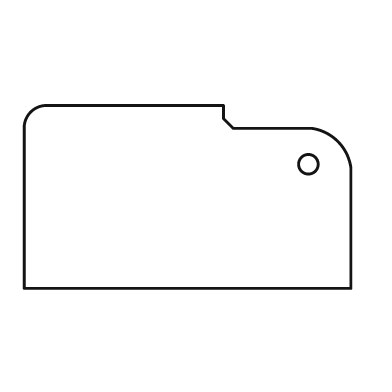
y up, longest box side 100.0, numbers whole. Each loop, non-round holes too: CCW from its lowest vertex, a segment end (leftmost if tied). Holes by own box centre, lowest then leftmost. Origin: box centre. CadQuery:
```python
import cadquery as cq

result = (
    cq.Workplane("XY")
    .moveTo(-50.0, -28.0)
    .lineTo(50.0, -28.0)
    .lineTo(50.0, 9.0)
    .threePointArc((46.0, 17.0), (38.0, 21.0))
    .lineTo(14.0, 21.0)
    .lineTo(11.0, 24.0)
    .lineTo(11.0, 28.0)
    .lineTo(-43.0, 28.0)
    .threePointArc((-48.0, 26.0), (-50.0, 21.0))
    .close()
    .moveTo(37.0, 10.0)
    .circle(3.0)
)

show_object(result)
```